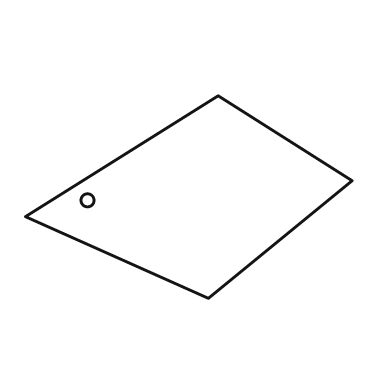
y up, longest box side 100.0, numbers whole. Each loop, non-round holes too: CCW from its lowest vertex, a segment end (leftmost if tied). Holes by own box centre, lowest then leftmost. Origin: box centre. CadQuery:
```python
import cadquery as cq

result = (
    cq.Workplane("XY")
    .moveTo(6.0, -31.0)
    .lineTo(50.0, 5.0)
    .lineTo(9.0, 31.0)
    .lineTo(-50.0, -6.0)
    .close()
    .moveTo(-31.0, -1.0)
    .circle(2.0)
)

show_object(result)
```